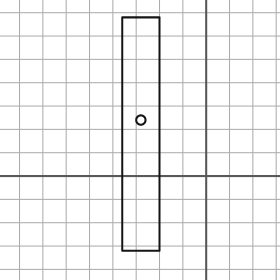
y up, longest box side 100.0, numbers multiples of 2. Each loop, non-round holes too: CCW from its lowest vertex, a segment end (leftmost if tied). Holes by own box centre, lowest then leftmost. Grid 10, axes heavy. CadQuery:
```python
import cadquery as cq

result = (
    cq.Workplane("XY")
    .moveTo(-36.0, -32.0)
    .lineTo(-20.0, -32.0)
    .lineTo(-20.0, 68.0)
    .lineTo(-36.0, 68.0)
    .close()
    .moveTo(-28.0, 24.0)
    .circle(2.0)
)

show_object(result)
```